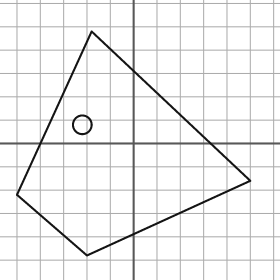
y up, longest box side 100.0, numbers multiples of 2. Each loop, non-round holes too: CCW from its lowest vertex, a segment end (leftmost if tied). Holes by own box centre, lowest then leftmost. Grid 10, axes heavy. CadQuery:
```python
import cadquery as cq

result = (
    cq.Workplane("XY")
    .moveTo(-20.0, -48.0)
    .lineTo(50.0, -16.0)
    .lineTo(-18.0, 48.0)
    .lineTo(-50.0, -22.0)
    .close()
    .moveTo(-22.0, 8.0)
    .circle(4.0)
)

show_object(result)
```